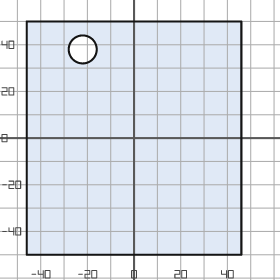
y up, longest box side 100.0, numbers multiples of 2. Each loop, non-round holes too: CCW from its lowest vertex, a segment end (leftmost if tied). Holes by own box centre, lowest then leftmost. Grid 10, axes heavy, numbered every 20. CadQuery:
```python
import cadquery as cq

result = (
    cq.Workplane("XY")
    .moveTo(-46.0, -50.0)
    .lineTo(46.0, -50.0)
    .lineTo(46.0, 50.0)
    .lineTo(-46.0, 50.0)
    .close()
    .moveTo(-22.0, 38.0)
    .circle(6.0)
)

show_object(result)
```